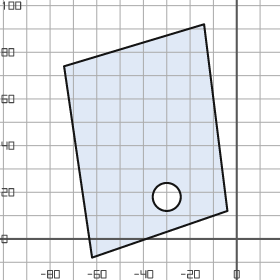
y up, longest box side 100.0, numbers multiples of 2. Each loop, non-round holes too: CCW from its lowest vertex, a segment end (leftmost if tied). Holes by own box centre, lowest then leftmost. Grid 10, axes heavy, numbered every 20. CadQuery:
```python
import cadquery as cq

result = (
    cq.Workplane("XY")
    .moveTo(-62.0, -8.0)
    .lineTo(-4.0, 12.0)
    .lineTo(-14.0, 92.0)
    .lineTo(-74.0, 74.0)
    .close()
    .moveTo(-30.0, 18.0)
    .circle(6.0)
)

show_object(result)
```